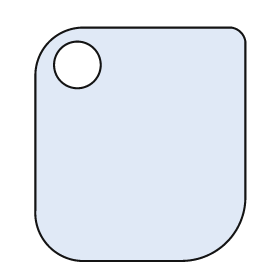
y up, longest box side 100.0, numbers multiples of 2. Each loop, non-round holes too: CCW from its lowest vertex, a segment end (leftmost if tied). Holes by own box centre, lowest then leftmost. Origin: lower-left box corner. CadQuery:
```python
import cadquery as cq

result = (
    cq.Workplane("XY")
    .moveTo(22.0, 0.0)
    .lineTo(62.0, 0.0)
    .threePointArc((82.0, 8.0), (90.0, 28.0))
    .lineTo(90.0, 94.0)
    .threePointArc((88.0, 98.0), (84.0, 100.0))
    .lineTo(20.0, 100.0)
    .threePointArc((6.0, 94.0), (0.0, 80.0))
    .lineTo(0.0, 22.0)
    .threePointArc((6.0, 6.0), (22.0, 0.0))
    .close()
    .moveTo(18.0, 84.0)
    .circle(10.0)
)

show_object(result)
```